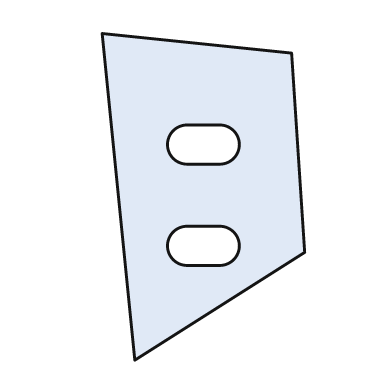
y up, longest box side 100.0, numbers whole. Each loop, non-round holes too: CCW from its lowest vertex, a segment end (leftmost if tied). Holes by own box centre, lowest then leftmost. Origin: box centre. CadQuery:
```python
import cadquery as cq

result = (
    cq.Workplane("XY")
    .moveTo(-21.0, -50.0)
    .lineTo(31.0, -17.0)
    .lineTo(27.0, 44.0)
    .lineTo(-31.0, 50.0)
    .close()
    .moveTo(-5.0, -21.0)
    .lineTo(5.0, -21.0)
    .threePointArc((11.0, -15.0), (5.0, -9.0))
    .lineTo(-5.0, -9.0)
    .threePointArc((-11.0, -15.0), (-5.0, -21.0))
    .close()
    .moveTo(-5.0, 10.0)
    .lineTo(5.0, 10.0)
    .threePointArc((11.0, 16.0), (5.0, 22.0))
    .lineTo(-5.0, 22.0)
    .threePointArc((-11.0, 16.0), (-5.0, 10.0))
    .close()
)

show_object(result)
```